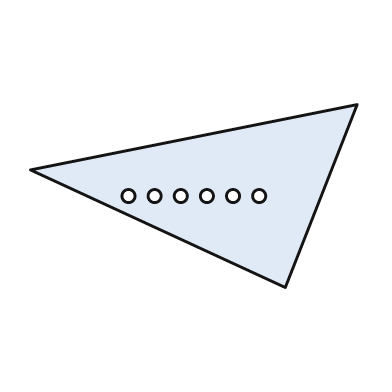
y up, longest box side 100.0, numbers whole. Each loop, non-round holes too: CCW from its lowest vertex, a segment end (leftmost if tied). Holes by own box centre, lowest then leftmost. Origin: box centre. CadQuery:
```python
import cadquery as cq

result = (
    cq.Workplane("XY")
    .moveTo(28.0, -28.0)
    .lineTo(50.0, 28.0)
    .lineTo(-50.0, 8.0)
    .close()
    .moveTo(-20.0, 0.0)
    .circle(2.0)
    .moveTo(-12.0, 0.0)
    .circle(2.0)
    .moveTo(-4.0, 0.0)
    .circle(2.0)
    .moveTo(4.0, 0.0)
    .circle(2.0)
    .moveTo(12.0, 0.0)
    .circle(2.0)
    .moveTo(20.0, 0.0)
    .circle(2.0)
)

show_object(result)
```